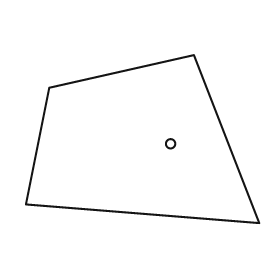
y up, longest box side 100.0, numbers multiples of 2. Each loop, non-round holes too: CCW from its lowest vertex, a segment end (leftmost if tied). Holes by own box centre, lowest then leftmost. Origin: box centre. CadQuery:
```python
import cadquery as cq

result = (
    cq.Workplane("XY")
    .moveTo(50.0, -36.0)
    .lineTo(22.0, 36.0)
    .lineTo(-40.0, 22.0)
    .lineTo(-50.0, -28.0)
    .close()
    .moveTo(12.0, -2.0)
    .circle(2.0)
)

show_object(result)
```